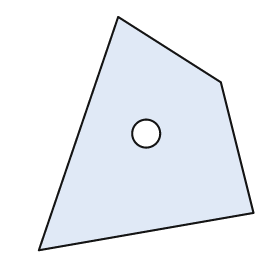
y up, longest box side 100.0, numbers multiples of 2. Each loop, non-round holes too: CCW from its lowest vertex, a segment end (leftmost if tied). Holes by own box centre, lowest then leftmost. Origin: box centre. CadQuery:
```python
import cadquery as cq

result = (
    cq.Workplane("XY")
    .moveTo(-46.0, -50.0)
    .lineTo(46.0, -34.0)
    .lineTo(32.0, 22.0)
    .lineTo(-12.0, 50.0)
    .close()
    .moveTo(0.0, 0.0)
    .circle(6.0)
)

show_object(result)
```